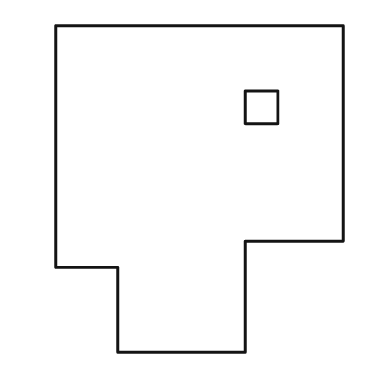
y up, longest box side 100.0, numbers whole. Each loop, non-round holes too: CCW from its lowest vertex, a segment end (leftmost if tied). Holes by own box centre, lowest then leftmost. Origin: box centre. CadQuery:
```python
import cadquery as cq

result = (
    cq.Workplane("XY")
    .moveTo(-25.0, -50.0)
    .lineTo(14.0, -50.0)
    .lineTo(14.0, -16.0)
    .lineTo(44.0, -16.0)
    .lineTo(44.0, 50.0)
    .lineTo(-44.0, 50.0)
    .lineTo(-44.0, -24.0)
    .lineTo(-25.0, -24.0)
    .close()
    .moveTo(14.0, 20.0)
    .lineTo(24.0, 20.0)
    .lineTo(24.0, 30.0)
    .lineTo(14.0, 30.0)
    .close()
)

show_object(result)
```